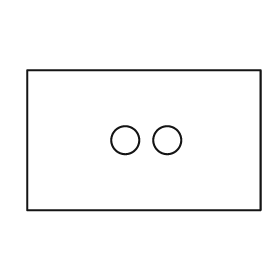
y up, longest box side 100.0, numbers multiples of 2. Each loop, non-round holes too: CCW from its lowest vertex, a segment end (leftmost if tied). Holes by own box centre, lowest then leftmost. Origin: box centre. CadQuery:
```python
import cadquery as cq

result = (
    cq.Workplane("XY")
    .moveTo(-50.0, -30.0)
    .lineTo(50.0, -30.0)
    .lineTo(50.0, 30.0)
    .lineTo(-50.0, 30.0)
    .close()
    .moveTo(-8.0, 0.0)
    .circle(6.0)
    .moveTo(10.0, 0.0)
    .circle(6.0)
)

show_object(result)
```